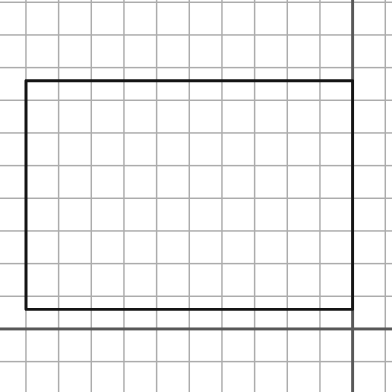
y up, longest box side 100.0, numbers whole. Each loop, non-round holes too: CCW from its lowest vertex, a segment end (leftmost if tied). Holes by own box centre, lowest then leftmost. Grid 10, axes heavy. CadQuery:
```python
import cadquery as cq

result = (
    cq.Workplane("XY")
    .moveTo(-100.0, 6.0)
    .lineTo(0.0, 6.0)
    .lineTo(0.0, 76.0)
    .lineTo(-100.0, 76.0)
    .close()
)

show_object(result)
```